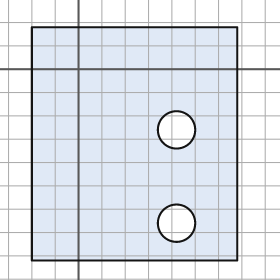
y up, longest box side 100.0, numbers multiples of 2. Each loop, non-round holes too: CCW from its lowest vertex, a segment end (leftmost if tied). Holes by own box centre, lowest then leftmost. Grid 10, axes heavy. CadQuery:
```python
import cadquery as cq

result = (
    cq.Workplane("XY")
    .moveTo(-20.0, -82.0)
    .lineTo(68.0, -82.0)
    .lineTo(68.0, 18.0)
    .lineTo(-20.0, 18.0)
    .close()
    .moveTo(42.0, -66.0)
    .circle(8.0)
    .moveTo(42.0, -26.0)
    .circle(8.0)
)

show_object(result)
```